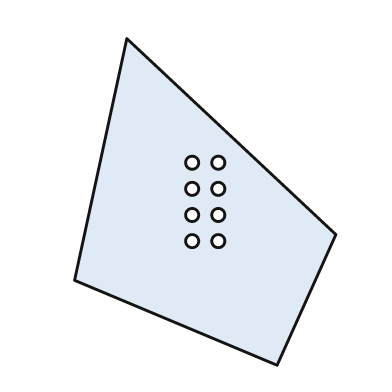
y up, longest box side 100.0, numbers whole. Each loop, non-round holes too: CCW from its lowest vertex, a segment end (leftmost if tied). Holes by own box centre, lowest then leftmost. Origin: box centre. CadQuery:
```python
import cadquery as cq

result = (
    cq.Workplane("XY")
    .moveTo(22.0, -50.0)
    .lineTo(40.0, -10.0)
    .lineTo(-24.0, 50.0)
    .lineTo(-40.0, -24.0)
    .close()
    .moveTo(-4.0, -12.0)
    .circle(2.0)
    .moveTo(4.0, -12.0)
    .circle(2.0)
    .moveTo(-4.0, -4.0)
    .circle(2.0)
    .moveTo(4.0, -4.0)
    .circle(2.0)
    .moveTo(-4.0, 4.0)
    .circle(2.0)
    .moveTo(4.0, 4.0)
    .circle(2.0)
    .moveTo(-4.0, 12.0)
    .circle(2.0)
    .moveTo(4.0, 12.0)
    .circle(2.0)
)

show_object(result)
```